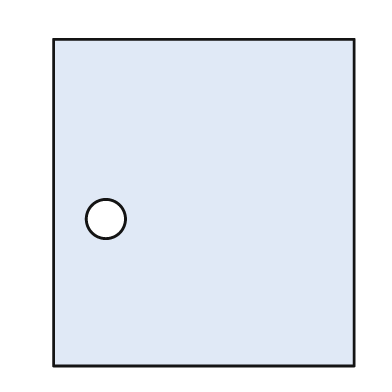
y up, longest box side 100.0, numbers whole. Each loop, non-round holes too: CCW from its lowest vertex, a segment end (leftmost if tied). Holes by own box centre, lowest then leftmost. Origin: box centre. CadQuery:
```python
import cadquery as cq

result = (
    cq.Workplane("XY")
    .moveTo(-46.0, -50.0)
    .lineTo(46.0, -50.0)
    .lineTo(46.0, 50.0)
    .lineTo(-46.0, 50.0)
    .close()
    .moveTo(-30.0, -5.0)
    .circle(6.0)
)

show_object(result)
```